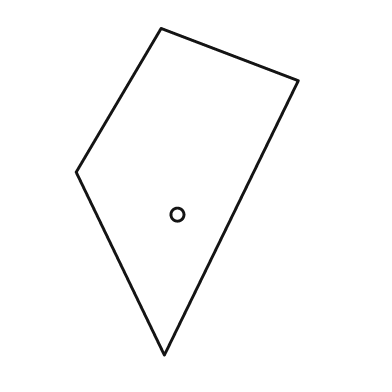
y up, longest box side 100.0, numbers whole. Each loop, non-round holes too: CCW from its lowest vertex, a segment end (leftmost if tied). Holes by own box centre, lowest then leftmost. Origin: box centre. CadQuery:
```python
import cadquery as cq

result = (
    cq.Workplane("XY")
    .moveTo(-7.0, -50.0)
    .lineTo(34.0, 34.0)
    .lineTo(-8.0, 50.0)
    .lineTo(-34.0, 6.0)
    .close()
    .moveTo(-3.0, -7.0)
    .circle(2.0)
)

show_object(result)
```